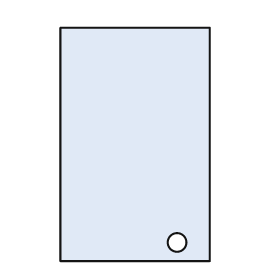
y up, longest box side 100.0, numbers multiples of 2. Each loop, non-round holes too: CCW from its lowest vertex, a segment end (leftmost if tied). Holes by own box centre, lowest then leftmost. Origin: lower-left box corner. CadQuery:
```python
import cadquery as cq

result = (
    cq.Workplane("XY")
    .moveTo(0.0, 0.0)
    .lineTo(64.0, 0.0)
    .lineTo(64.0, 100.0)
    .lineTo(0.0, 100.0)
    .close()
    .moveTo(50.0, 8.0)
    .circle(4.0)
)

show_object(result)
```